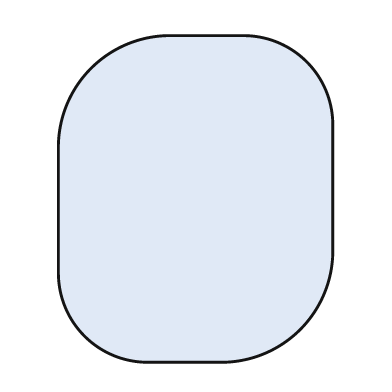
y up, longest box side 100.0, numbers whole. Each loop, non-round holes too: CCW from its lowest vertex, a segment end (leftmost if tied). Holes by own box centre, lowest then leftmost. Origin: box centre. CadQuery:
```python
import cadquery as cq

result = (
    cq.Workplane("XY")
    .moveTo(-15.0, -50.0)
    .lineTo(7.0, -50.0)
    .threePointArc((32.0, -40.0), (42.0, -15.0))
    .lineTo(42.0, 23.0)
    .threePointArc((34.0, 42.0), (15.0, 50.0))
    .lineTo(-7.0, 50.0)
    .threePointArc((-32.0, 40.0), (-42.0, 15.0))
    .lineTo(-42.0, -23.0)
    .threePointArc((-34.0, -42.0), (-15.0, -50.0))
    .close()
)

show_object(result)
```